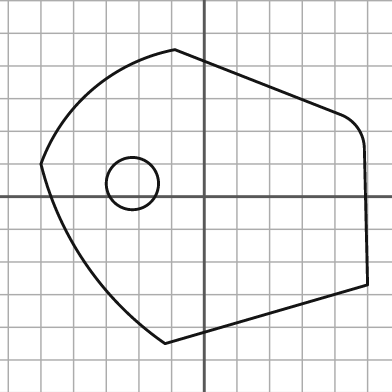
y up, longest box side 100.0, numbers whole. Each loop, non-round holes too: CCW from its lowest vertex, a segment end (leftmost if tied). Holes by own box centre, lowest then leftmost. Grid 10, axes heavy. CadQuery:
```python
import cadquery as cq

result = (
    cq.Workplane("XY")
    .moveTo(-12.0, -45.0)
    .lineTo(50.0, -27.0)
    .lineTo(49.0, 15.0)
    .threePointArc((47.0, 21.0), (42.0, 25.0))
    .lineTo(-9.0, 45.0)
    .threePointArc((-34.0, 33.0), (-50.0, 10.0))
    .threePointArc((-36.0, -21.0), (-12.0, -45.0))
    .close()
    .moveTo(-22.0, 4.0)
    .circle(8.0)
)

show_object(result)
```